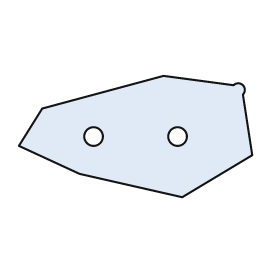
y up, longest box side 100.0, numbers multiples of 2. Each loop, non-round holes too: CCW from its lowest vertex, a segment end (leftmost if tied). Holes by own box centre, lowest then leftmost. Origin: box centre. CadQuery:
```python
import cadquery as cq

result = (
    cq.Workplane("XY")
    .moveTo(20.0, -26.0)
    .lineTo(50.0, -8.0)
    .lineTo(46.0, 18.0)
    .threePointArc((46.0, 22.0), (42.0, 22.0))
    .lineTo(12.0, 26.0)
    .lineTo(-40.0, 12.0)
    .lineTo(-50.0, -4.0)
    .lineTo(-24.0, -16.0)
    .close()
    .moveTo(-18.0, 0.0)
    .circle(4.0)
    .moveTo(18.0, 0.0)
    .circle(4.0)
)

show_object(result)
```